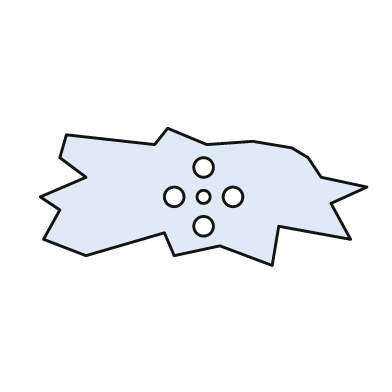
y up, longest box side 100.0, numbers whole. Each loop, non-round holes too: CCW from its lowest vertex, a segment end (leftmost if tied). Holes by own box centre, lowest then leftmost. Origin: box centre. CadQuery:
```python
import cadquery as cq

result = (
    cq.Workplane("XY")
    .moveTo(21.0, -21.0)
    .lineTo(23.0, -9.0)
    .lineTo(45.0, -13.0)
    .lineTo(39.0, -2.0)
    .lineTo(50.0, 3.0)
    .lineTo(36.0, 6.0)
    .lineTo(32.0, 12.0)
    .lineTo(27.0, 15.0)
    .lineTo(15.0, 17.0)
    .lineTo(1.0, 16.0)
    .lineTo(-11.0, 21.0)
    .lineTo(-15.0, 16.0)
    .lineTo(-42.0, 19.0)
    .lineTo(-44.0, 12.0)
    .lineTo(-36.0, 6.0)
    .lineTo(-50.0, 0.0)
    .lineTo(-44.0, -4.0)
    .lineTo(-49.0, -13.0)
    .lineTo(-36.0, -18.0)
    .lineTo(-12.0, -11.0)
    .lineTo(-9.0, -18.0)
    .lineTo(5.0, -15.0)
    .close()
    .moveTo(0.0, -9.0)
    .circle(3.0)
    .moveTo(-9.0, 0.0)
    .circle(3.0)
    .moveTo(0.0, 0.0)
    .circle(2.0)
    .moveTo(9.0, 0.0)
    .circle(3.0)
    .moveTo(0.0, 9.0)
    .circle(3.0)
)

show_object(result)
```